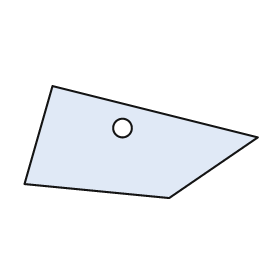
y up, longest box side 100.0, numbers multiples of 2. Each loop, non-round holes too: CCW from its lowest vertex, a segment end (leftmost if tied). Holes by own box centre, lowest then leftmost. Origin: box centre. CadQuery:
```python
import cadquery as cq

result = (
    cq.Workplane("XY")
    .moveTo(12.0, -24.0)
    .lineTo(50.0, 2.0)
    .lineTo(-38.0, 24.0)
    .lineTo(-50.0, -18.0)
    .close()
    .moveTo(-8.0, 6.0)
    .circle(4.0)
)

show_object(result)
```